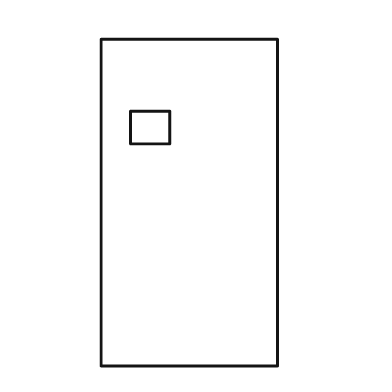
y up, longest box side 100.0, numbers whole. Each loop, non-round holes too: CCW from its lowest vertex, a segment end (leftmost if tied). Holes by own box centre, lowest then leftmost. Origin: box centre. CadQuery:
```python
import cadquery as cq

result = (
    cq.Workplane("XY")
    .moveTo(-27.0, -50.0)
    .lineTo(27.0, -50.0)
    .lineTo(27.0, 50.0)
    .lineTo(-27.0, 50.0)
    .close()
    .moveTo(-18.0, 18.0)
    .lineTo(-6.0, 18.0)
    .lineTo(-6.0, 28.0)
    .lineTo(-18.0, 28.0)
    .close()
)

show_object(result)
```